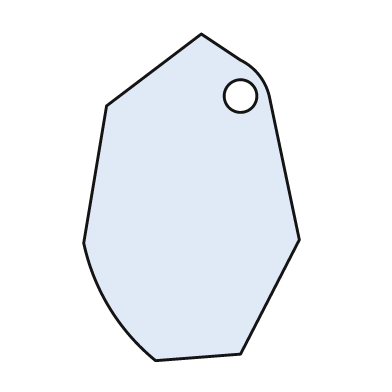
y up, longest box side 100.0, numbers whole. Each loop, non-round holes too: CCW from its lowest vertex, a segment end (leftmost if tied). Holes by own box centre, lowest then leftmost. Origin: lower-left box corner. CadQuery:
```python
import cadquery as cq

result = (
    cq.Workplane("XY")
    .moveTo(22.0, 0.0)
    .lineTo(48.0, 2.0)
    .lineTo(66.0, 37.0)
    .lineTo(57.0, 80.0)
    .threePointArc((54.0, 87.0), (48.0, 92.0))
    .lineTo(36.0, 100.0)
    .lineTo(7.0, 78.0)
    .lineTo(0.0, 36.0)
    .threePointArc((8.0, 16.0), (22.0, 0.0))
    .close()
    .moveTo(48.0, 81.0)
    .circle(5.0)
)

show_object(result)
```